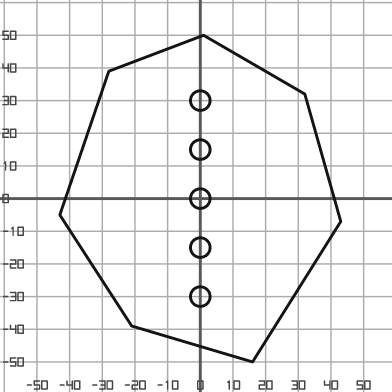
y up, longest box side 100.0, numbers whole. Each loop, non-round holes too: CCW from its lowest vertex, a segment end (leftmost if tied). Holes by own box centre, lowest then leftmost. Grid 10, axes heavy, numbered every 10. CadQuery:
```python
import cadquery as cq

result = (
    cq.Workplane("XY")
    .moveTo(16.0, -50.0)
    .lineTo(43.0, -7.0)
    .lineTo(32.0, 32.0)
    .lineTo(1.0, 50.0)
    .lineTo(-28.0, 39.0)
    .lineTo(-43.0, -5.0)
    .lineTo(-21.0, -39.0)
    .close()
    .moveTo(0.0, -30.0)
    .circle(3.0)
    .moveTo(0.0, -15.0)
    .circle(3.0)
    .moveTo(0.0, 0.0)
    .circle(3.0)
    .moveTo(0.0, 15.0)
    .circle(3.0)
    .moveTo(0.0, 30.0)
    .circle(3.0)
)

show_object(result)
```